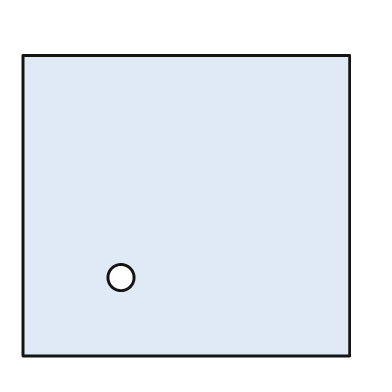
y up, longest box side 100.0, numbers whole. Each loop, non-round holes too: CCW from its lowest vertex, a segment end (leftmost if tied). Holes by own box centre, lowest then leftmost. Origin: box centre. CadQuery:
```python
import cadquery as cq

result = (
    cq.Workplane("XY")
    .moveTo(-50.0, -46.0)
    .lineTo(50.0, -46.0)
    .lineTo(50.0, 46.0)
    .lineTo(-50.0, 46.0)
    .close()
    .moveTo(-20.0, -22.0)
    .circle(4.0)
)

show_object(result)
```